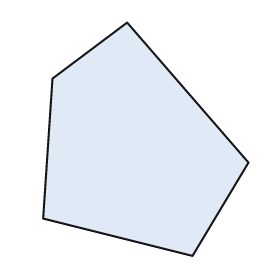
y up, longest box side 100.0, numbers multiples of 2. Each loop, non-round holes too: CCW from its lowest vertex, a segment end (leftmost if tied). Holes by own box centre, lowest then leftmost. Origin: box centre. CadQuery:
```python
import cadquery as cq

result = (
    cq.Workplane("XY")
    .moveTo(20.0, -50.0)
    .lineTo(44.0, -10.0)
    .lineTo(-8.0, 50.0)
    .lineTo(-40.0, 26.0)
    .lineTo(-44.0, -34.0)
    .close()
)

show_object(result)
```